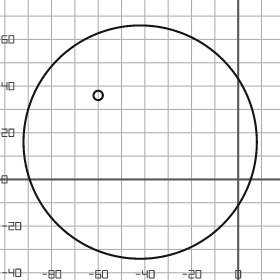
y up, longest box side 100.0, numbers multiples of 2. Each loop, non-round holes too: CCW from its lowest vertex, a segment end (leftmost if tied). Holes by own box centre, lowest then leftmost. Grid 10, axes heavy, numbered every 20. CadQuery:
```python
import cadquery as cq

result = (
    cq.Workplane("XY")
    .moveTo(-42.0, 16.0)
    .circle(50.0)
    .moveTo(-60.0, 36.0)
    .circle(2.0)
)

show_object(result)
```